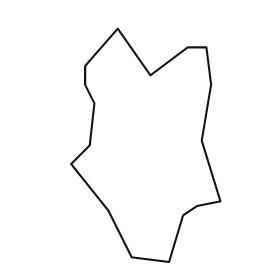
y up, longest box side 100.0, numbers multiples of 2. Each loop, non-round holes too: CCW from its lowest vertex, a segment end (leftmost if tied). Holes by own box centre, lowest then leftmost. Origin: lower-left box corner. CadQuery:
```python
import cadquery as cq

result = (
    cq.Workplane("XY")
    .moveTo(42.0, 0.0)
    .lineTo(48.0, 20.0)
    .lineTo(54.0, 24.0)
    .lineTo(64.0, 26.0)
    .lineTo(56.0, 52.0)
    .lineTo(60.0, 76.0)
    .lineTo(58.0, 92.0)
    .lineTo(50.0, 92.0)
    .lineTo(34.0, 80.0)
    .lineTo(20.0, 100.0)
    .lineTo(6.0, 84.0)
    .lineTo(6.0, 76.0)
    .lineTo(10.0, 68.0)
    .lineTo(8.0, 50.0)
    .lineTo(0.0, 42.0)
    .lineTo(16.0, 22.0)
    .lineTo(26.0, 2.0)
    .close()
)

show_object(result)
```